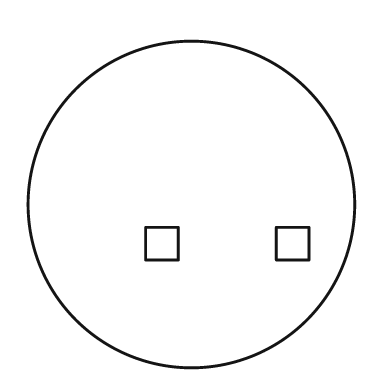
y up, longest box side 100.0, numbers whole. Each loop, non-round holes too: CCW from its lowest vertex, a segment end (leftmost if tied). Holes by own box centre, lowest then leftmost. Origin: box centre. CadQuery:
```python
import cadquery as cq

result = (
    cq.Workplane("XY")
    .moveTo(0.0, 0.0)
    .circle(50.0)
    .moveTo(-14.0, -17.0)
    .lineTo(-4.0, -17.0)
    .lineTo(-4.0, -7.0)
    .lineTo(-14.0, -7.0)
    .close()
    .moveTo(26.0, -17.0)
    .lineTo(36.0, -17.0)
    .lineTo(36.0, -7.0)
    .lineTo(26.0, -7.0)
    .close()
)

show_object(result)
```